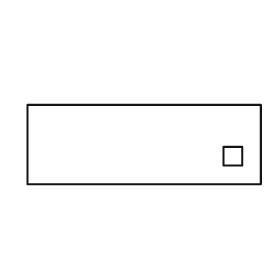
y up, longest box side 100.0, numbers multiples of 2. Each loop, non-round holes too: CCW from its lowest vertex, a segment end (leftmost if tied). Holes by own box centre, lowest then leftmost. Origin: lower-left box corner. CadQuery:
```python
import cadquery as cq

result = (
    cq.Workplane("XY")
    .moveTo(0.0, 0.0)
    .lineTo(100.0, 0.0)
    .lineTo(100.0, 34.0)
    .lineTo(0.0, 34.0)
    .close()
    .moveTo(84.0, 8.0)
    .lineTo(92.0, 8.0)
    .lineTo(92.0, 16.0)
    .lineTo(84.0, 16.0)
    .close()
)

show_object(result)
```